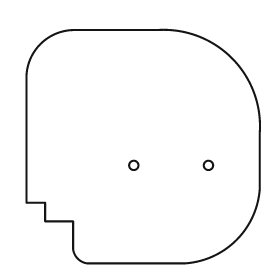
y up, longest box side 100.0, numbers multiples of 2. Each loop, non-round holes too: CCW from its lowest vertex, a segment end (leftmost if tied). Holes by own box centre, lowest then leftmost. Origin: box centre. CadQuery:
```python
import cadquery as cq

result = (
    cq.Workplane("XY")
    .moveTo(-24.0, -50.0)
    .lineTo(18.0, -50.0)
    .threePointArc((40.0, -40.0), (50.0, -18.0))
    .lineTo(50.0, 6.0)
    .threePointArc((38.0, 38.0), (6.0, 50.0))
    .lineTo(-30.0, 50.0)
    .threePointArc((-44.0, 44.0), (-50.0, 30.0))
    .lineTo(-50.0, -24.0)
    .lineTo(-42.0, -24.0)
    .lineTo(-42.0, -32.0)
    .lineTo(-30.0, -32.0)
    .lineTo(-30.0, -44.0)
    .threePointArc((-28.0, -48.0), (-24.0, -50.0))
    .close()
    .moveTo(-4.0, -8.0)
    .circle(2.0)
    .moveTo(28.0, -8.0)
    .circle(2.0)
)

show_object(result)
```